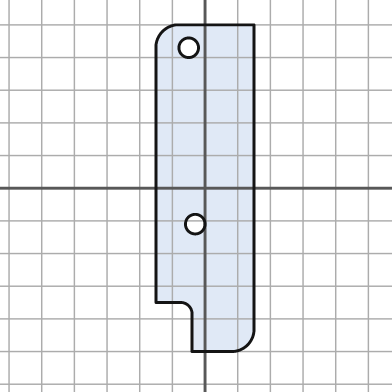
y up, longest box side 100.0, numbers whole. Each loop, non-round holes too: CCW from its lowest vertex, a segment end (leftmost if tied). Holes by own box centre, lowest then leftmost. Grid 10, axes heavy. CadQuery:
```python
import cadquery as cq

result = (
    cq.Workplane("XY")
    .moveTo(-4.0, -50.0)
    .lineTo(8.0, -50.0)
    .threePointArc((13.0, -48.0), (15.0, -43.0))
    .lineTo(15.0, 50.0)
    .lineTo(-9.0, 50.0)
    .threePointArc((-13.0, 48.0), (-15.0, 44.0))
    .lineTo(-15.0, -35.0)
    .lineTo(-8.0, -35.0)
    .threePointArc((-5.0, -36.0), (-4.0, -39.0))
    .close()
    .moveTo(-3.0, -11.0)
    .circle(3.0)
    .moveTo(-5.0, 43.0)
    .circle(3.0)
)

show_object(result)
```